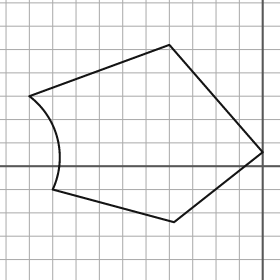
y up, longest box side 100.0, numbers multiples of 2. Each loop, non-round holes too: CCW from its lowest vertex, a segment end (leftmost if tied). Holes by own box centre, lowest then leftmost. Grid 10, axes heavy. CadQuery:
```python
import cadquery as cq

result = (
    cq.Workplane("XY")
    .moveTo(-38.0, -24.0)
    .lineTo(0.0, 6.0)
    .lineTo(-40.0, 52.0)
    .lineTo(-100.0, 30.0)
    .threePointArc((-88.0, 12.0), (-90.0, -10.0))
    .close()
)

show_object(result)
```